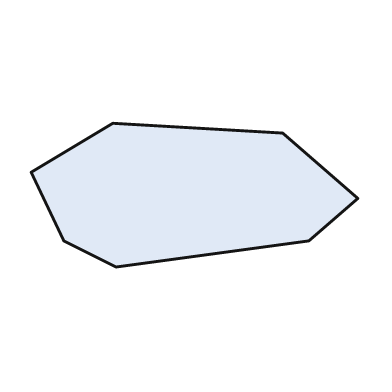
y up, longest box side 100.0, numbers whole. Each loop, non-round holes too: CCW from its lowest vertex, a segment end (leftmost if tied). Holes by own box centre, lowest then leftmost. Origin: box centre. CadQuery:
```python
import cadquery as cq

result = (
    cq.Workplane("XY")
    .moveTo(-24.0, -22.0)
    .lineTo(35.0, -14.0)
    .lineTo(50.0, -1.0)
    .lineTo(27.0, 19.0)
    .lineTo(-25.0, 22.0)
    .lineTo(-50.0, 7.0)
    .lineTo(-40.0, -14.0)
    .close()
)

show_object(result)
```